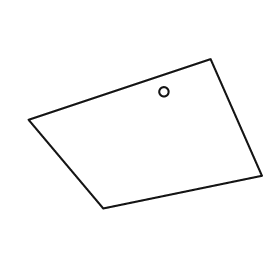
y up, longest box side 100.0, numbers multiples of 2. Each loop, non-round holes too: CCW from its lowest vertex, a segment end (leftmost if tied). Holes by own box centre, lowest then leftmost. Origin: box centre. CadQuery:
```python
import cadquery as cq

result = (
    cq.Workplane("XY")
    .moveTo(-18.0, -32.0)
    .lineTo(50.0, -18.0)
    .lineTo(28.0, 32.0)
    .lineTo(-50.0, 6.0)
    .close()
    .moveTo(8.0, 18.0)
    .circle(2.0)
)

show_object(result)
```